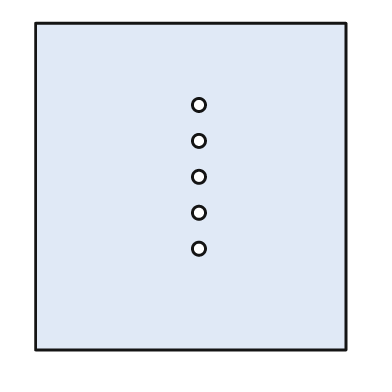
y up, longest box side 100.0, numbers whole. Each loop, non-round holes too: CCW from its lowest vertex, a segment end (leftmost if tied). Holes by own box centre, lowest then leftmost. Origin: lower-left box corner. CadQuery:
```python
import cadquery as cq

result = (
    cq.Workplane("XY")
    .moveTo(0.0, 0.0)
    .lineTo(95.0, 0.0)
    .lineTo(95.0, 100.0)
    .lineTo(0.0, 100.0)
    .close()
    .moveTo(50.0, 31.0)
    .circle(2.0)
    .moveTo(50.0, 42.0)
    .circle(2.0)
    .moveTo(50.0, 53.0)
    .circle(2.0)
    .moveTo(50.0, 64.0)
    .circle(2.0)
    .moveTo(50.0, 75.0)
    .circle(2.0)
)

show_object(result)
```